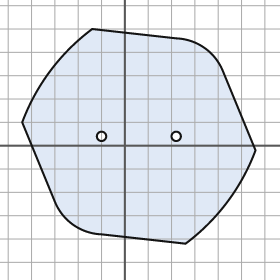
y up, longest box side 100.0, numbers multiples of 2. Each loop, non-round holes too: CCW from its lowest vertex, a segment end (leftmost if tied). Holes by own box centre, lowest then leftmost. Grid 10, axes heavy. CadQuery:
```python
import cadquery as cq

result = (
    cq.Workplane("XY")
    .moveTo(26.0, -42.0)
    .threePointArc((44.0, -24.0), (56.0, -2.0))
    .lineTo(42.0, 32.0)
    .threePointArc((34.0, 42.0), (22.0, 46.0))
    .lineTo(-14.0, 50.0)
    .threePointArc((-32.0, 32.0), (-44.0, 10.0))
    .lineTo(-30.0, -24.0)
    .threePointArc((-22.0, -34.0), (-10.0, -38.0))
    .close()
    .moveTo(-10.0, 4.0)
    .circle(2.0)
    .moveTo(22.0, 4.0)
    .circle(2.0)
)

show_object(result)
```